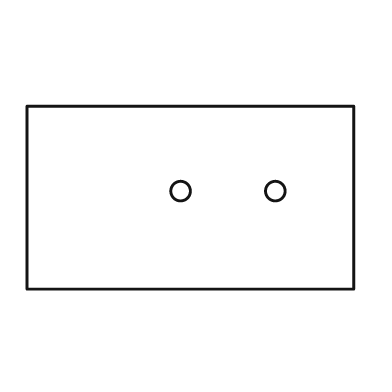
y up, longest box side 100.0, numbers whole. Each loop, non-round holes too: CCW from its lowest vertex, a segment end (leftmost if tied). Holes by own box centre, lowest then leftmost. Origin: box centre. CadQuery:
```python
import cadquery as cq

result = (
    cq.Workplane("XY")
    .moveTo(-50.0, -28.0)
    .lineTo(50.0, -28.0)
    .lineTo(50.0, 28.0)
    .lineTo(-50.0, 28.0)
    .close()
    .moveTo(-3.0, 2.0)
    .circle(3.0)
    .moveTo(26.0, 2.0)
    .circle(3.0)
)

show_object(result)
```